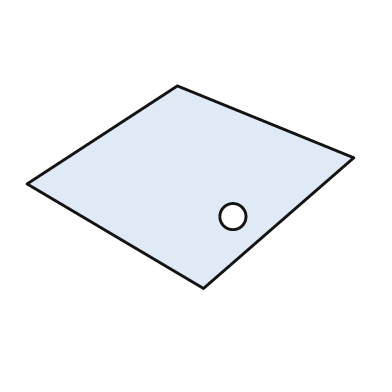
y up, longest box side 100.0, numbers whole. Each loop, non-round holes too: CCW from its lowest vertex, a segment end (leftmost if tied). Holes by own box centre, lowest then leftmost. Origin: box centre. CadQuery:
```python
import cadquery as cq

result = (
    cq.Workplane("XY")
    .moveTo(4.0, -31.0)
    .lineTo(50.0, 9.0)
    .lineTo(-4.0, 31.0)
    .lineTo(-50.0, 1.0)
    .close()
    .moveTo(13.0, -9.0)
    .circle(4.0)
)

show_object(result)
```